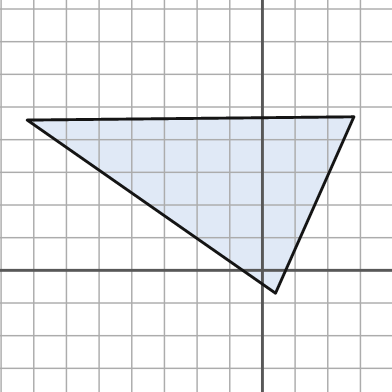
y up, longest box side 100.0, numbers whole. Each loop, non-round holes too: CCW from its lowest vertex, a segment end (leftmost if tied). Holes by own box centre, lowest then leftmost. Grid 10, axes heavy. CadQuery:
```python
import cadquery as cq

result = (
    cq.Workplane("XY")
    .moveTo(4.0, -7.0)
    .lineTo(28.0, 47.0)
    .lineTo(-72.0, 46.0)
    .close()
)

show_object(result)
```